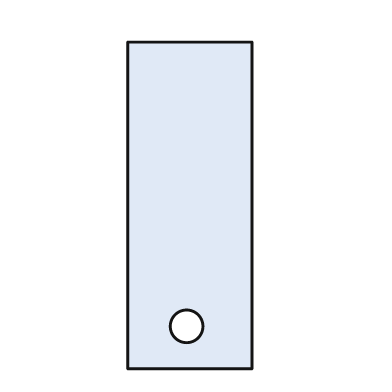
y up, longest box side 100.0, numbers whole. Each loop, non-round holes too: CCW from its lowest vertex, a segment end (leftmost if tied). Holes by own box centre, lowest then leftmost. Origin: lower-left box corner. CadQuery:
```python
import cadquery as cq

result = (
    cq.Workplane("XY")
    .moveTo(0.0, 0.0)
    .lineTo(38.0, 0.0)
    .lineTo(38.0, 100.0)
    .lineTo(0.0, 100.0)
    .close()
    .moveTo(18.0, 13.0)
    .circle(5.0)
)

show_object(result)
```